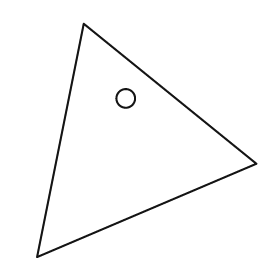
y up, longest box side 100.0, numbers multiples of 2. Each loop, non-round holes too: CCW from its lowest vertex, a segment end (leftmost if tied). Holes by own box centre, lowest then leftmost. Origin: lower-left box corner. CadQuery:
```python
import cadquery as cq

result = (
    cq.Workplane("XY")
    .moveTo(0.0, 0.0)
    .lineTo(94.0, 40.0)
    .lineTo(20.0, 100.0)
    .close()
    .moveTo(38.0, 68.0)
    .circle(4.0)
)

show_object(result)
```